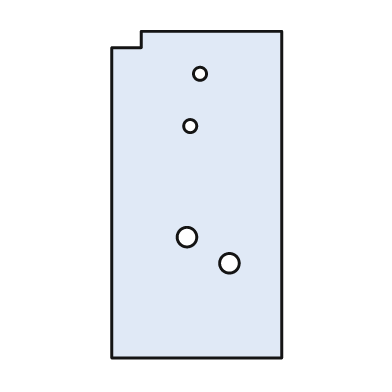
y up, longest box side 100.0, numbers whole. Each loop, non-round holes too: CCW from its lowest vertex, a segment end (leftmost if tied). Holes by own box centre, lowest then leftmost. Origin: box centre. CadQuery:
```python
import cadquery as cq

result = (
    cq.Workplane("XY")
    .moveTo(-26.0, -50.0)
    .lineTo(26.0, -50.0)
    .lineTo(26.0, 50.0)
    .lineTo(-17.0, 50.0)
    .lineTo(-17.0, 45.0)
    .lineTo(-26.0, 45.0)
    .close()
    .moveTo(10.0, -21.0)
    .circle(3.0)
    .moveTo(-3.0, -13.0)
    .circle(3.0)
    .moveTo(-2.0, 21.0)
    .circle(2.0)
    .moveTo(1.0, 37.0)
    .circle(2.0)
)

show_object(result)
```